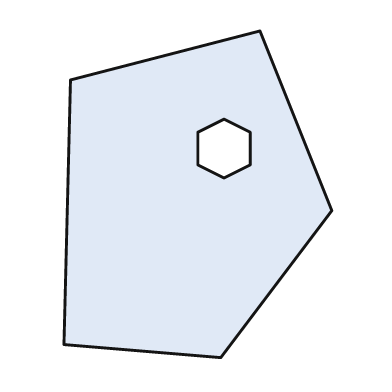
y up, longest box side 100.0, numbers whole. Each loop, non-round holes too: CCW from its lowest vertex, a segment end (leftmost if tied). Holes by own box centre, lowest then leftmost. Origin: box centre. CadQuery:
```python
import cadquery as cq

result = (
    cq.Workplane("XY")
    .moveTo(7.0, -50.0)
    .lineTo(41.0, -5.0)
    .lineTo(19.0, 50.0)
    .lineTo(-39.0, 35.0)
    .lineTo(-41.0, -46.0)
    .close()
    .moveTo(8.0, 5.0)
    .lineTo(16.0, 9.0)
    .lineTo(16.0, 19.0)
    .lineTo(8.0, 23.0)
    .lineTo(0.0, 19.0)
    .lineTo(0.0, 9.0)
    .close()
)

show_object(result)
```